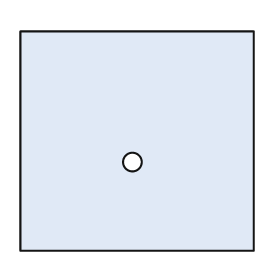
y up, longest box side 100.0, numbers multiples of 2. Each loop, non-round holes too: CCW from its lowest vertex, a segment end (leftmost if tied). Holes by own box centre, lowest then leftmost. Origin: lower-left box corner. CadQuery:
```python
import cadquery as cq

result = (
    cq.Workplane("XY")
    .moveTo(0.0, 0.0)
    .lineTo(100.0, 0.0)
    .lineTo(100.0, 94.0)
    .lineTo(0.0, 94.0)
    .close()
    .moveTo(48.0, 38.0)
    .circle(4.0)
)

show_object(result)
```